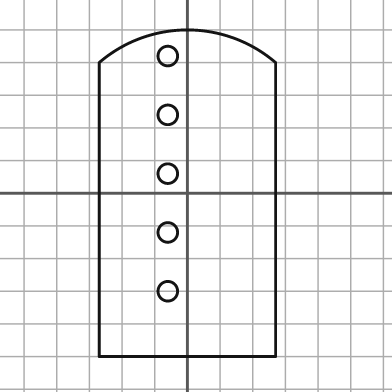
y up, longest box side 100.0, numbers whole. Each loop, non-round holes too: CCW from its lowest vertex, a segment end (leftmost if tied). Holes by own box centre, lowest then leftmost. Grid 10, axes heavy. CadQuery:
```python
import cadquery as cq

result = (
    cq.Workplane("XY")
    .moveTo(-27.0, -50.0)
    .lineTo(27.0, -50.0)
    .lineTo(27.0, 40.0)
    .threePointArc((0.0, 50.0), (-27.0, 40.0))
    .close()
    .moveTo(-6.0, -30.0)
    .circle(3.0)
    .moveTo(-6.0, -12.0)
    .circle(3.0)
    .moveTo(-6.0, 6.0)
    .circle(3.0)
    .moveTo(-6.0, 24.0)
    .circle(3.0)
    .moveTo(-6.0, 42.0)
    .circle(3.0)
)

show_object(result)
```